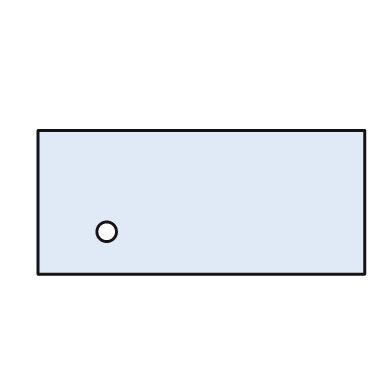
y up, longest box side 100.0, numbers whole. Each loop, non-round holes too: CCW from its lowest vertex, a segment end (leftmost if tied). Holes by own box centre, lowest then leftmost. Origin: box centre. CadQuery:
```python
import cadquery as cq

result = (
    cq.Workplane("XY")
    .moveTo(-50.0, -22.0)
    .lineTo(50.0, -22.0)
    .lineTo(50.0, 22.0)
    .lineTo(-50.0, 22.0)
    .close()
    .moveTo(-29.0, -9.0)
    .circle(3.0)
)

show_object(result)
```